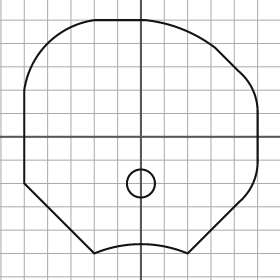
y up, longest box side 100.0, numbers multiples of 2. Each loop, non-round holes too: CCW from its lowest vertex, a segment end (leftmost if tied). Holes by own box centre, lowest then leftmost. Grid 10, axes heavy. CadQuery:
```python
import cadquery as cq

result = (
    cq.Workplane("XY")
    .moveTo(-20.0, -50.0)
    .threePointArc((0.0, -46.0), (20.0, -50.0))
    .lineTo(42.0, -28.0)
    .threePointArc((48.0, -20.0), (50.0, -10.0))
    .lineTo(50.0, 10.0)
    .threePointArc((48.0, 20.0), (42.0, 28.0))
    .lineTo(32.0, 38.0)
    .threePointArc((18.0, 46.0), (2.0, 50.0))
    .lineTo(-20.0, 50.0)
    .threePointArc((-40.0, 40.0), (-50.0, 20.0))
    .lineTo(-50.0, -20.0)
    .close()
    .moveTo(0.0, -20.0)
    .circle(6.0)
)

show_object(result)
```